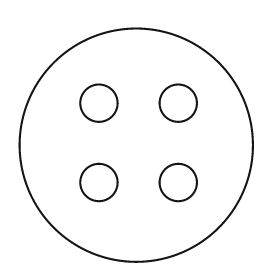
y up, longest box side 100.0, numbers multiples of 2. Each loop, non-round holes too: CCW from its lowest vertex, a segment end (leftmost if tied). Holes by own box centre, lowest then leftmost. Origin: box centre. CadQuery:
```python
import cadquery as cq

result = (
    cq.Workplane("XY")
    .moveTo(0.0, 0.0)
    .circle(50.0)
    .moveTo(-16.0, -16.0)
    .circle(8.0)
    .moveTo(18.0, -16.0)
    .circle(8.0)
    .moveTo(-16.0, 18.0)
    .circle(8.0)
    .moveTo(18.0, 18.0)
    .circle(8.0)
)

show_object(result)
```